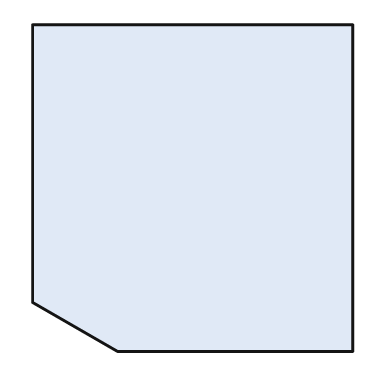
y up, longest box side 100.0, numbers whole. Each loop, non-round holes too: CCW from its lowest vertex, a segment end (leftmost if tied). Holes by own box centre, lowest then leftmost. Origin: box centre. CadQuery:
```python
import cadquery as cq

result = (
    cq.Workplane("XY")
    .moveTo(-23.0, -50.0)
    .lineTo(49.0, -50.0)
    .lineTo(49.0, 50.0)
    .lineTo(-49.0, 50.0)
    .lineTo(-49.0, -35.0)
    .close()
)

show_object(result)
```